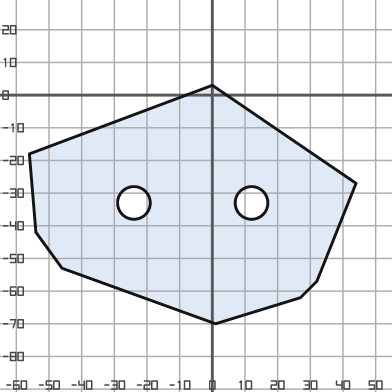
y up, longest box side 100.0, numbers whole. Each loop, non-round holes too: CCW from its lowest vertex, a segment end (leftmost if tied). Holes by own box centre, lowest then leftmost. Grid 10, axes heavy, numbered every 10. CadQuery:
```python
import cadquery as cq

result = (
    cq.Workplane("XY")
    .moveTo(1.0, -70.0)
    .lineTo(27.0, -62.0)
    .lineTo(32.0, -57.0)
    .lineTo(44.0, -27.0)
    .lineTo(0.0, 3.0)
    .lineTo(-56.0, -18.0)
    .lineTo(-54.0, -42.0)
    .lineTo(-46.0, -53.0)
    .close()
    .moveTo(-24.0, -33.0)
    .circle(5.0)
    .moveTo(12.0, -33.0)
    .circle(5.0)
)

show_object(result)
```